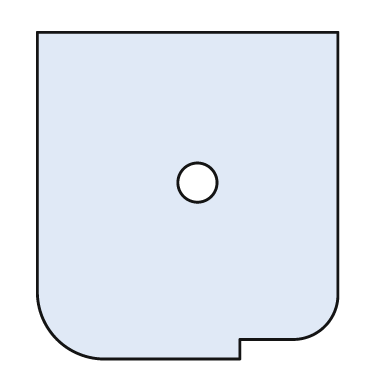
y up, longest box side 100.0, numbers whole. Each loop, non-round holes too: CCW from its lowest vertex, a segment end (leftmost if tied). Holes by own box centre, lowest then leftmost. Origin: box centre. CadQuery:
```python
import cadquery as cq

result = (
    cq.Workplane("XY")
    .moveTo(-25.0, -50.0)
    .lineTo(16.0, -50.0)
    .lineTo(16.0, -44.0)
    .lineTo(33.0, -44.0)
    .threePointArc((42.0, -40.0), (46.0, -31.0))
    .lineTo(46.0, 50.0)
    .lineTo(-46.0, 50.0)
    .lineTo(-46.0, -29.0)
    .threePointArc((-40.0, -44.0), (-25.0, -50.0))
    .close()
    .moveTo(3.0, 4.0)
    .circle(6.0)
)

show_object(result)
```